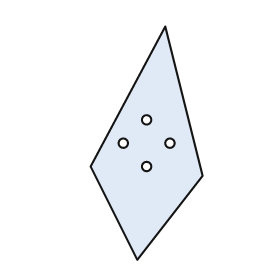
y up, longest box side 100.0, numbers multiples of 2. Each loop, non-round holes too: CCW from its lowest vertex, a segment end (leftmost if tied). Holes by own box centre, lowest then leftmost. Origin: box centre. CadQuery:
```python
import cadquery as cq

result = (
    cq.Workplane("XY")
    .moveTo(-4.0, -50.0)
    .lineTo(24.0, -14.0)
    .lineTo(8.0, 50.0)
    .lineTo(-24.0, -10.0)
    .close()
    .moveTo(0.0, -10.0)
    .circle(2.0)
    .moveTo(-10.0, 0.0)
    .circle(2.0)
    .moveTo(10.0, 0.0)
    .circle(2.0)
    .moveTo(0.0, 10.0)
    .circle(2.0)
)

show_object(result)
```